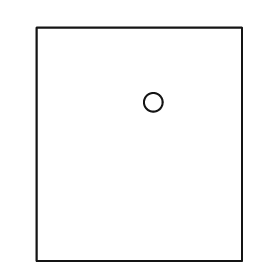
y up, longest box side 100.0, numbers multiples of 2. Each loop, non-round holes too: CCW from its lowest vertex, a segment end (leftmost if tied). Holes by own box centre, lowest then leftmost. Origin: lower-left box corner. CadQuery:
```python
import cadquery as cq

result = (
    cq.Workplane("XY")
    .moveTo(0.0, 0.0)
    .lineTo(88.0, 0.0)
    .lineTo(88.0, 100.0)
    .lineTo(0.0, 100.0)
    .close()
    .moveTo(50.0, 68.0)
    .circle(4.0)
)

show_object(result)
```